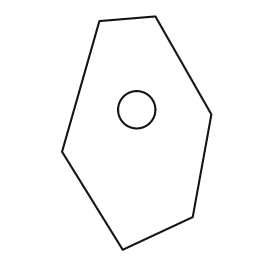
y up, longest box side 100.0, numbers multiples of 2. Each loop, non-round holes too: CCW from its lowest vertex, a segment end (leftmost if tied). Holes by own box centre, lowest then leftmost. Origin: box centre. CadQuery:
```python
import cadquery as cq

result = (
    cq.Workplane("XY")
    .moveTo(-6.0, -50.0)
    .lineTo(24.0, -36.0)
    .lineTo(32.0, 8.0)
    .lineTo(8.0, 50.0)
    .lineTo(-16.0, 48.0)
    .lineTo(-32.0, -8.0)
    .close()
    .moveTo(0.0, 10.0)
    .circle(8.0)
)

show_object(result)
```